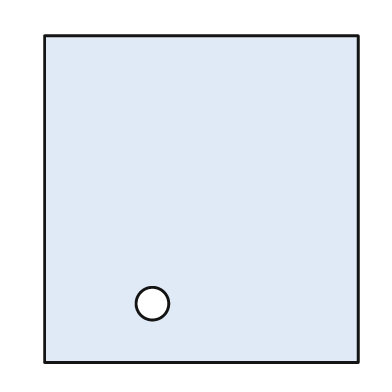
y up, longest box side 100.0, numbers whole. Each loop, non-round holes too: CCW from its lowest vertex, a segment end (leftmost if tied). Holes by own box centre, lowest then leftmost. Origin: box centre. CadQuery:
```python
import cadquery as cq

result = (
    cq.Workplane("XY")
    .moveTo(-48.0, -50.0)
    .lineTo(48.0, -50.0)
    .lineTo(48.0, 50.0)
    .lineTo(-48.0, 50.0)
    .close()
    .moveTo(-15.0, -32.0)
    .circle(5.0)
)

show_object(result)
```